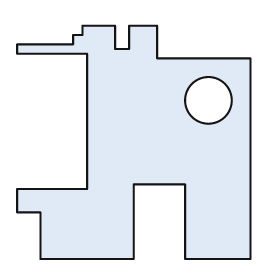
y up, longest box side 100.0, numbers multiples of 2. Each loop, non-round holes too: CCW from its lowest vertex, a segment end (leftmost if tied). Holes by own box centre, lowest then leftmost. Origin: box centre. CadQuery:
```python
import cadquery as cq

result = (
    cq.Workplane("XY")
    .moveTo(-40.0, -50.0)
    .lineTo(0.0, -50.0)
    .lineTo(0.0, -18.0)
    .lineTo(22.0, -18.0)
    .lineTo(22.0, -50.0)
    .lineTo(50.0, -50.0)
    .lineTo(50.0, 36.0)
    .lineTo(10.0, 36.0)
    .lineTo(10.0, 50.0)
    .lineTo(-2.0, 50.0)
    .lineTo(-2.0, 40.0)
    .lineTo(-8.0, 40.0)
    .lineTo(-8.0, 50.0)
    .lineTo(-22.0, 50.0)
    .lineTo(-22.0, 46.0)
    .lineTo(-26.0, 46.0)
    .lineTo(-26.0, 42.0)
    .lineTo(-50.0, 42.0)
    .lineTo(-50.0, 38.0)
    .lineTo(-20.0, 38.0)
    .lineTo(-20.0, -20.0)
    .lineTo(-50.0, -20.0)
    .lineTo(-50.0, -30.0)
    .lineTo(-40.0, -30.0)
    .close()
    .moveTo(32.0, 18.0)
    .circle(10.0)
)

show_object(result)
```